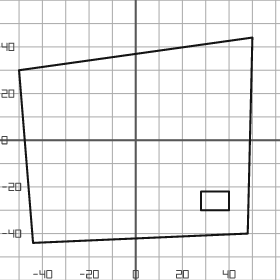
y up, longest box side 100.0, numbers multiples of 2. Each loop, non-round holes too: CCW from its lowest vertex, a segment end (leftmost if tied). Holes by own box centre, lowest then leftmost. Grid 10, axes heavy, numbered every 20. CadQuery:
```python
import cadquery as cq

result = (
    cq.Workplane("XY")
    .moveTo(-44.0, -44.0)
    .lineTo(48.0, -40.0)
    .lineTo(50.0, 44.0)
    .lineTo(-50.0, 30.0)
    .close()
    .moveTo(28.0, -30.0)
    .lineTo(40.0, -30.0)
    .lineTo(40.0, -22.0)
    .lineTo(28.0, -22.0)
    .close()
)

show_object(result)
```